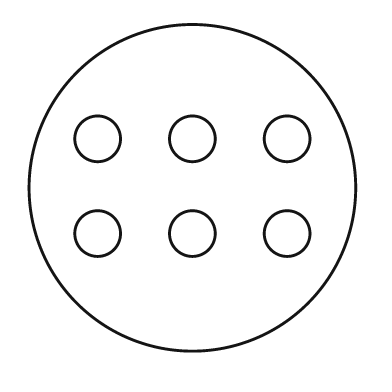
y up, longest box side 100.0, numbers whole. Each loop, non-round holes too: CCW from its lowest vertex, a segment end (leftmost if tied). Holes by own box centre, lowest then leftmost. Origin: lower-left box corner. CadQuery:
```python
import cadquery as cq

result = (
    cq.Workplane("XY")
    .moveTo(50.0, 50.0)
    .circle(50.0)
    .moveTo(21.0, 36.0)
    .circle(7.0)
    .moveTo(50.0, 36.0)
    .circle(7.0)
    .moveTo(79.0, 36.0)
    .circle(7.0)
    .moveTo(21.0, 65.0)
    .circle(7.0)
    .moveTo(50.0, 65.0)
    .circle(7.0)
    .moveTo(79.0, 65.0)
    .circle(7.0)
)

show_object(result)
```